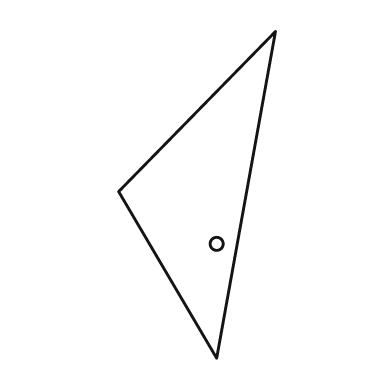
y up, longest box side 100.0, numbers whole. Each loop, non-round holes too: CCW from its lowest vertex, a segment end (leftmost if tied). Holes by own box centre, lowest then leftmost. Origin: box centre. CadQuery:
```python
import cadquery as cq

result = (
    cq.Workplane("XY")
    .moveTo(6.0, -50.0)
    .lineTo(24.0, 50.0)
    .lineTo(-24.0, 1.0)
    .close()
    .moveTo(6.0, -15.0)
    .circle(2.0)
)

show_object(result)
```